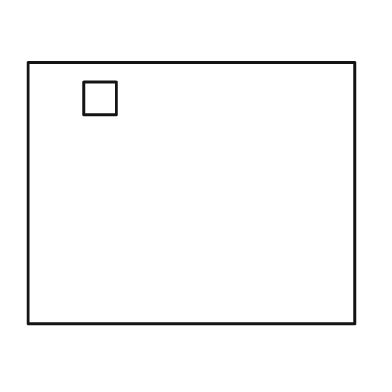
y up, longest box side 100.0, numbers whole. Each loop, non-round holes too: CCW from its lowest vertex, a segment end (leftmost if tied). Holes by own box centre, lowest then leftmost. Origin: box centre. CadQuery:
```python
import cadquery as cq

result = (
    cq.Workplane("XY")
    .moveTo(-50.0, -40.0)
    .lineTo(50.0, -40.0)
    .lineTo(50.0, 40.0)
    .lineTo(-50.0, 40.0)
    .close()
    .moveTo(-33.0, 24.0)
    .lineTo(-23.0, 24.0)
    .lineTo(-23.0, 34.0)
    .lineTo(-33.0, 34.0)
    .close()
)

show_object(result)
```